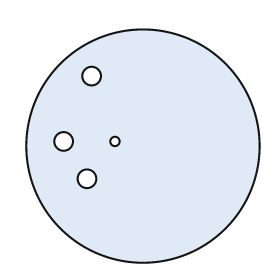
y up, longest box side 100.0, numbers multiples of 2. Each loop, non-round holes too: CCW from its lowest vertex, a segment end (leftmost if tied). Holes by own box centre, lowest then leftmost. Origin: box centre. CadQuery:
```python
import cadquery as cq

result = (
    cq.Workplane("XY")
    .moveTo(0.0, 0.0)
    .circle(50.0)
    .moveTo(-24.0, -14.0)
    .circle(4.0)
    .moveTo(-34.0, 2.0)
    .circle(4.0)
    .moveTo(-12.0, 2.0)
    .circle(2.0)
    .moveTo(-22.0, 30.0)
    .circle(4.0)
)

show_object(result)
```